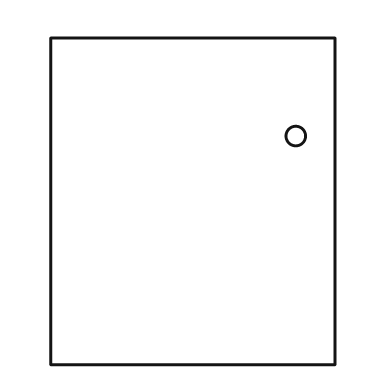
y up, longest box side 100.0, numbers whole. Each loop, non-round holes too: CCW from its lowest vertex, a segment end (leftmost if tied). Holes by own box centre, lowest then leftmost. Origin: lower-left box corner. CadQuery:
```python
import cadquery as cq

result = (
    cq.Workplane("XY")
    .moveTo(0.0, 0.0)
    .lineTo(87.0, 0.0)
    .lineTo(87.0, 100.0)
    .lineTo(0.0, 100.0)
    .close()
    .moveTo(75.0, 70.0)
    .circle(3.0)
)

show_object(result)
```